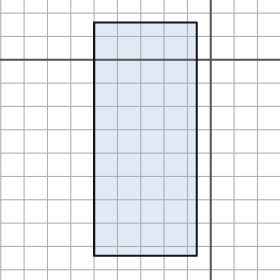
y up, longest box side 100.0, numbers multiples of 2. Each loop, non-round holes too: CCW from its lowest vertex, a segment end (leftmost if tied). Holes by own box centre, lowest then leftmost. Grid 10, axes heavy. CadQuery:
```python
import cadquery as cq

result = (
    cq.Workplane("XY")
    .moveTo(-50.0, -84.0)
    .lineTo(-6.0, -84.0)
    .lineTo(-6.0, 16.0)
    .lineTo(-50.0, 16.0)
    .close()
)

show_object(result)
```